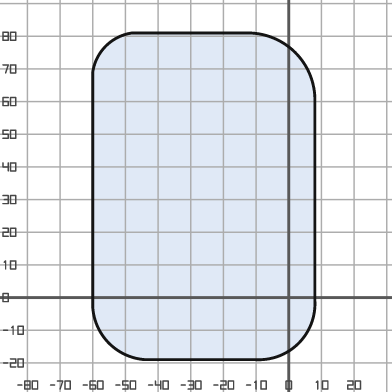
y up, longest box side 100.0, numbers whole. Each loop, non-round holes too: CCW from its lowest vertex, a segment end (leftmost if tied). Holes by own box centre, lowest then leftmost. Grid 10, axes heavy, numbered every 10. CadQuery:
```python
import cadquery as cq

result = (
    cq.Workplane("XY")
    .moveTo(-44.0, -19.0)
    .lineTo(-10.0, -19.0)
    .threePointArc((3.0, -14.0), (8.0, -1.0))
    .lineTo(8.0, 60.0)
    .threePointArc((2.0, 75.0), (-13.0, 81.0))
    .lineTo(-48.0, 81.0)
    .threePointArc((-56.0, 77.0), (-60.0, 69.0))
    .lineTo(-60.0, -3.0)
    .threePointArc((-55.0, -14.0), (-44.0, -19.0))
    .close()
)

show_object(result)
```